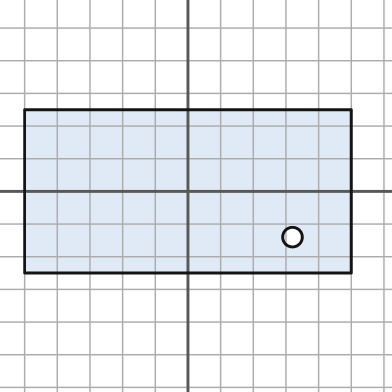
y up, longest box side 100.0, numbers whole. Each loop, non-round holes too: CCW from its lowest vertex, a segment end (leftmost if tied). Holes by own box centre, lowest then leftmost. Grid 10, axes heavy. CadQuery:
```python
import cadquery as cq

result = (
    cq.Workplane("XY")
    .moveTo(-50.0, -25.0)
    .lineTo(50.0, -25.0)
    .lineTo(50.0, 25.0)
    .lineTo(-50.0, 25.0)
    .close()
    .moveTo(32.0, -14.0)
    .circle(3.0)
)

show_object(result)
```